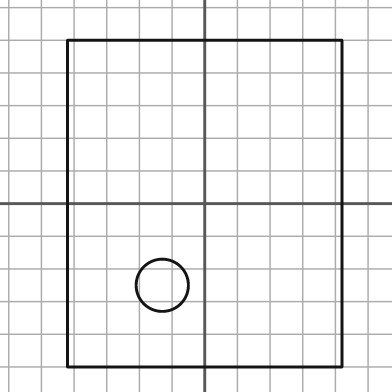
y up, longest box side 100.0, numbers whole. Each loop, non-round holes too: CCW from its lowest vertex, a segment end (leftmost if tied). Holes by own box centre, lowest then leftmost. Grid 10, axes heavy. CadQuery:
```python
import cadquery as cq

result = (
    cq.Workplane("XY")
    .moveTo(-42.0, -50.0)
    .lineTo(42.0, -50.0)
    .lineTo(42.0, 50.0)
    .lineTo(-42.0, 50.0)
    .close()
    .moveTo(-13.0, -25.0)
    .circle(8.0)
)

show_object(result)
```